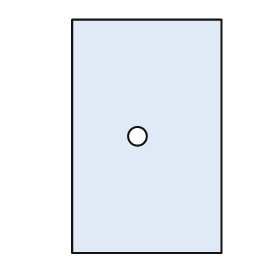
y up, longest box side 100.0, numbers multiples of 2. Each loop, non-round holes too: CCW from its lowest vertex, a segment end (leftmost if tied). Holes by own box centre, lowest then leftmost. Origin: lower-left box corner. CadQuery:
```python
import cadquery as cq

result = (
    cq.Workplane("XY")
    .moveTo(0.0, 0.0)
    .lineTo(64.0, 0.0)
    .lineTo(64.0, 100.0)
    .lineTo(0.0, 100.0)
    .close()
    .moveTo(28.0, 50.0)
    .circle(4.0)
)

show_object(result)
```